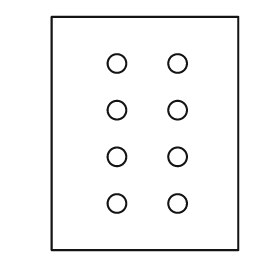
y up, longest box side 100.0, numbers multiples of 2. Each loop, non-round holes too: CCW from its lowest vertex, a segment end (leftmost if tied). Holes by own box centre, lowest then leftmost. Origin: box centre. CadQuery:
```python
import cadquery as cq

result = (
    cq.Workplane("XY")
    .moveTo(-40.0, -50.0)
    .lineTo(40.0, -50.0)
    .lineTo(40.0, 50.0)
    .lineTo(-40.0, 50.0)
    .close()
    .moveTo(-12.0, -30.0)
    .circle(4.0)
    .moveTo(14.0, -30.0)
    .circle(4.0)
    .moveTo(-12.0, -10.0)
    .circle(4.0)
    .moveTo(14.0, -10.0)
    .circle(4.0)
    .moveTo(-12.0, 10.0)
    .circle(4.0)
    .moveTo(14.0, 10.0)
    .circle(4.0)
    .moveTo(-12.0, 30.0)
    .circle(4.0)
    .moveTo(14.0, 30.0)
    .circle(4.0)
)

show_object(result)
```